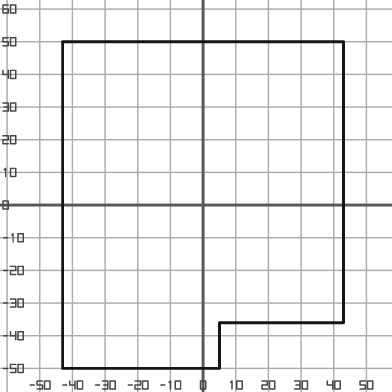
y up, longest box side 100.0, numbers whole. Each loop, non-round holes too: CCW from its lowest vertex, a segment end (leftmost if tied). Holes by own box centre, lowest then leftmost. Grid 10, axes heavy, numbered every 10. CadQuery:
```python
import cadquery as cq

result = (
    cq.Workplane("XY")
    .moveTo(-43.0, -50.0)
    .lineTo(5.0, -50.0)
    .lineTo(5.0, -36.0)
    .lineTo(43.0, -36.0)
    .lineTo(43.0, 50.0)
    .lineTo(-43.0, 50.0)
    .close()
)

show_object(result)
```